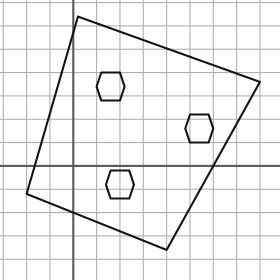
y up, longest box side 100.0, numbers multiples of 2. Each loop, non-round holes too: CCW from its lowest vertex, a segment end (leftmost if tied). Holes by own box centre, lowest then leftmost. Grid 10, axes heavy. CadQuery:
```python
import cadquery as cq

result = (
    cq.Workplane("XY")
    .moveTo(40.0, -36.0)
    .lineTo(80.0, 36.0)
    .lineTo(2.0, 64.0)
    .lineTo(-20.0, -12.0)
    .close()
    .moveTo(16.0, -14.0)
    .lineTo(24.0, -14.0)
    .lineTo(26.0, -8.0)
    .lineTo(24.0, -2.0)
    .lineTo(16.0, -2.0)
    .lineTo(14.0, -8.0)
    .close()
    .moveTo(50.0, 10.0)
    .lineTo(58.0, 10.0)
    .lineTo(60.0, 16.0)
    .lineTo(58.0, 22.0)
    .lineTo(50.0, 22.0)
    .lineTo(48.0, 16.0)
    .close()
    .moveTo(12.0, 28.0)
    .lineTo(20.0, 28.0)
    .lineTo(22.0, 34.0)
    .lineTo(20.0, 40.0)
    .lineTo(12.0, 40.0)
    .lineTo(10.0, 34.0)
    .close()
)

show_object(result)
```